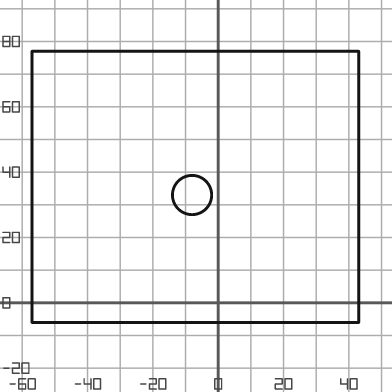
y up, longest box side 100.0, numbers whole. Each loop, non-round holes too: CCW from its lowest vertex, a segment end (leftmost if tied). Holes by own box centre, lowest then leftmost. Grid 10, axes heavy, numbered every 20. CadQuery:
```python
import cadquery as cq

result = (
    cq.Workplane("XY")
    .moveTo(-57.0, -6.0)
    .lineTo(43.0, -6.0)
    .lineTo(43.0, 77.0)
    .lineTo(-57.0, 77.0)
    .close()
    .moveTo(-8.0, 33.0)
    .circle(6.0)
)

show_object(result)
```